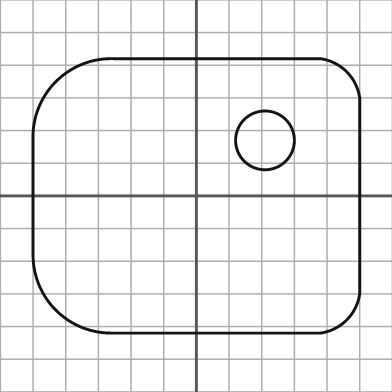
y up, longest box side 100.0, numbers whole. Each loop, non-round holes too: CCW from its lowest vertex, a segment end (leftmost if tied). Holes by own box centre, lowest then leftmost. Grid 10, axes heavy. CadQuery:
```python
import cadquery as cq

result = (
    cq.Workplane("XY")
    .moveTo(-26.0, -42.0)
    .lineTo(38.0, -42.0)
    .threePointArc((46.0, -38.0), (50.0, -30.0))
    .lineTo(50.0, 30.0)
    .threePointArc((46.0, 38.0), (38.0, 42.0))
    .lineTo(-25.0, 42.0)
    .threePointArc((-43.0, 35.0), (-50.0, 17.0))
    .lineTo(-50.0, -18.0)
    .threePointArc((-43.0, -35.0), (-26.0, -42.0))
    .close()
    .moveTo(21.0, 17.0)
    .circle(9.0)
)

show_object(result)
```